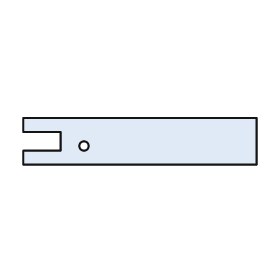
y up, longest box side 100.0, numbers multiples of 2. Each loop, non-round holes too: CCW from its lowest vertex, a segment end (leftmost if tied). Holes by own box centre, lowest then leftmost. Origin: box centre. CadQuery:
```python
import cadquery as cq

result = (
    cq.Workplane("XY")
    .moveTo(-50.0, -10.0)
    .lineTo(50.0, -10.0)
    .lineTo(50.0, 10.0)
    .lineTo(-50.0, 10.0)
    .lineTo(-50.0, 4.0)
    .lineTo(-34.0, 4.0)
    .lineTo(-34.0, -4.0)
    .lineTo(-50.0, -4.0)
    .close()
    .moveTo(-24.0, -2.0)
    .circle(2.0)
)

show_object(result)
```